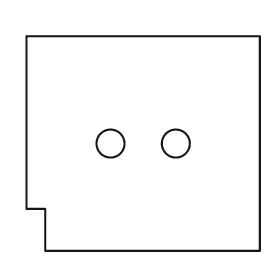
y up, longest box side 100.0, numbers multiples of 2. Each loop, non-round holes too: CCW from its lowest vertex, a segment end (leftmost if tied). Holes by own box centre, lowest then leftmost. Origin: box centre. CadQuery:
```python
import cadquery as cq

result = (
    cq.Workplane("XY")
    .moveTo(-42.0, -46.0)
    .lineTo(50.0, -46.0)
    .lineTo(50.0, 46.0)
    .lineTo(-50.0, 46.0)
    .lineTo(-50.0, -28.0)
    .lineTo(-42.0, -28.0)
    .close()
    .moveTo(-14.0, 0.0)
    .circle(6.0)
    .moveTo(14.0, 0.0)
    .circle(6.0)
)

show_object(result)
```